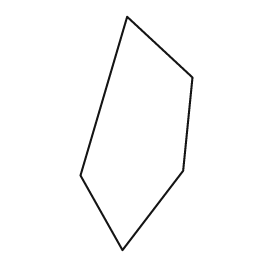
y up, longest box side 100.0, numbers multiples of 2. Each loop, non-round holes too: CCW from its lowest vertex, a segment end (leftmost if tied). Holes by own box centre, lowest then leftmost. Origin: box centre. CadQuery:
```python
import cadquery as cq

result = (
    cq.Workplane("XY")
    .moveTo(-6.0, -50.0)
    .lineTo(20.0, -16.0)
    .lineTo(24.0, 24.0)
    .lineTo(-4.0, 50.0)
    .lineTo(-24.0, -18.0)
    .close()
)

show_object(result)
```